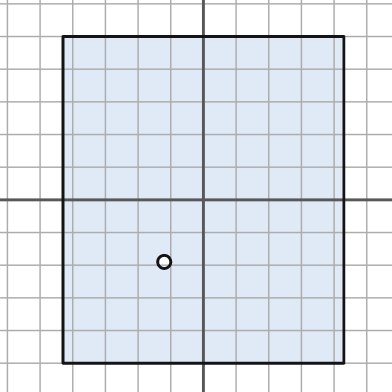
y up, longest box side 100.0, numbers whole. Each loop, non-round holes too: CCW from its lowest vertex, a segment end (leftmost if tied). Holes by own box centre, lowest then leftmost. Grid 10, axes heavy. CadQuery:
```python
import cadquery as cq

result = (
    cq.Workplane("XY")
    .moveTo(-43.0, -50.0)
    .lineTo(43.0, -50.0)
    .lineTo(43.0, 50.0)
    .lineTo(-43.0, 50.0)
    .close()
    .moveTo(-12.0, -19.0)
    .circle(2.0)
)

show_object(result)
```